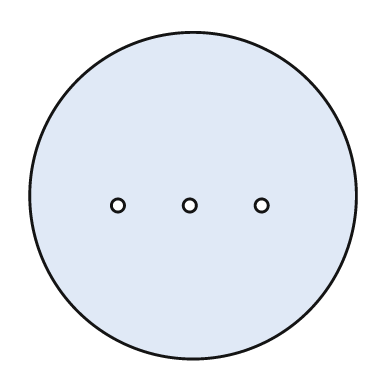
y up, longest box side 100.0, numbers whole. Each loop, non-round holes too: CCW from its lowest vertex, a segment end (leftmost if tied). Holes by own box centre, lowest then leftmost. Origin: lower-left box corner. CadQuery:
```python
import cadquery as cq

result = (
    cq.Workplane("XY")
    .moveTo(50.0, 50.0)
    .circle(50.0)
    .moveTo(27.0, 47.0)
    .circle(2.0)
    .moveTo(49.0, 47.0)
    .circle(2.0)
    .moveTo(71.0, 47.0)
    .circle(2.0)
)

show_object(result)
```